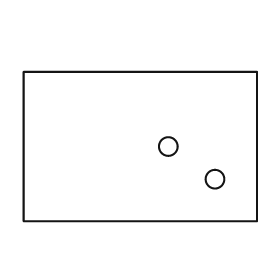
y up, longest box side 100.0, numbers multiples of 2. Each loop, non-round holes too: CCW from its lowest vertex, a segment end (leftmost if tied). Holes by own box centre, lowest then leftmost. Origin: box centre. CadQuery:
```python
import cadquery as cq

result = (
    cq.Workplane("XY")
    .moveTo(-50.0, -32.0)
    .lineTo(50.0, -32.0)
    .lineTo(50.0, 32.0)
    .lineTo(-50.0, 32.0)
    .close()
    .moveTo(32.0, -14.0)
    .circle(4.0)
    .moveTo(12.0, 0.0)
    .circle(4.0)
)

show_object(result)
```